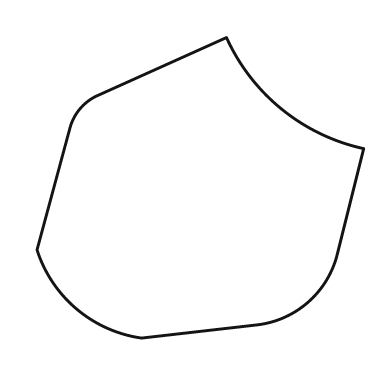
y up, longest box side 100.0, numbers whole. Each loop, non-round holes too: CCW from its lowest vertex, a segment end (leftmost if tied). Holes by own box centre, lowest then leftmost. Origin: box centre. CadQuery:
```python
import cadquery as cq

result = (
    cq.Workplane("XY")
    .moveTo(-18.0, -46.0)
    .lineTo(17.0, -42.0)
    .threePointArc((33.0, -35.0), (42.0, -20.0))
    .lineTo(50.0, 12.0)
    .threePointArc((25.0, 24.0), (8.0, 46.0))
    .lineTo(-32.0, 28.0)
    .threePointArc((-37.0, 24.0), (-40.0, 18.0))
    .lineTo(-50.0, -19.0)
    .threePointArc((-38.0, -37.0), (-18.0, -46.0))
    .close()
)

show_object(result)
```